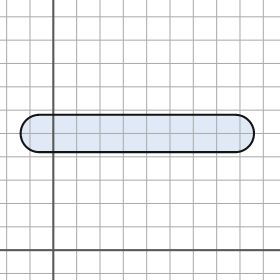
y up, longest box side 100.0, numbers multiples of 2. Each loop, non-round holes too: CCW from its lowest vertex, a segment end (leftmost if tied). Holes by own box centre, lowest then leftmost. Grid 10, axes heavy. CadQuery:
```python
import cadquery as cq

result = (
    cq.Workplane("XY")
    .moveTo(-6.0, 42.0)
    .lineTo(78.0, 42.0)
    .threePointArc((86.0, 50.0), (78.0, 58.0))
    .lineTo(-6.0, 58.0)
    .threePointArc((-14.0, 50.0), (-6.0, 42.0))
    .close()
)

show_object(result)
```